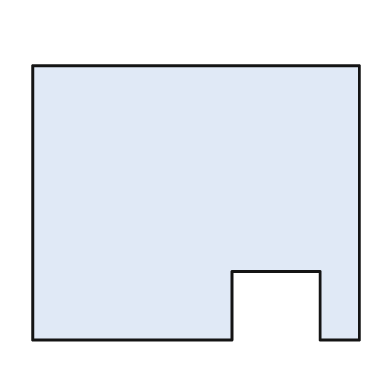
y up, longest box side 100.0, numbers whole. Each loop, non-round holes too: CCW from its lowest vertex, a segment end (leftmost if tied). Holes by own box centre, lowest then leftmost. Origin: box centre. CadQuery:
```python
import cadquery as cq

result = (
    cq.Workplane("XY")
    .moveTo(-50.0, -42.0)
    .lineTo(11.0, -42.0)
    .lineTo(11.0, -21.0)
    .lineTo(38.0, -21.0)
    .lineTo(38.0, -42.0)
    .lineTo(50.0, -42.0)
    .lineTo(50.0, 42.0)
    .lineTo(-50.0, 42.0)
    .close()
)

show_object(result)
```